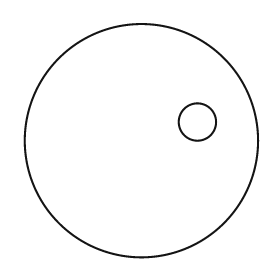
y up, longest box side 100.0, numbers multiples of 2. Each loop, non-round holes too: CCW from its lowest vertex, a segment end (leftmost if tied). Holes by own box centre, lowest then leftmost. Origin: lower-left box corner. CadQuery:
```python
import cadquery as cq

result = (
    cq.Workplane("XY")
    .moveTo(50.0, 50.0)
    .circle(50.0)
    .moveTo(74.0, 58.0)
    .circle(8.0)
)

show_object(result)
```